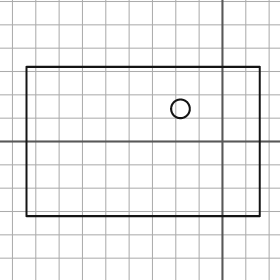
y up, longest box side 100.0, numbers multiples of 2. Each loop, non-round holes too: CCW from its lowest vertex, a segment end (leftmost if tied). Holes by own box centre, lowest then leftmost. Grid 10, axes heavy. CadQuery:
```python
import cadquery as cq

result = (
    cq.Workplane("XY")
    .moveTo(-84.0, -32.0)
    .lineTo(16.0, -32.0)
    .lineTo(16.0, 32.0)
    .lineTo(-84.0, 32.0)
    .close()
    .moveTo(-18.0, 14.0)
    .circle(4.0)
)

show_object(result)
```